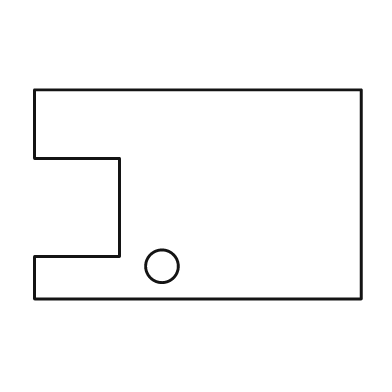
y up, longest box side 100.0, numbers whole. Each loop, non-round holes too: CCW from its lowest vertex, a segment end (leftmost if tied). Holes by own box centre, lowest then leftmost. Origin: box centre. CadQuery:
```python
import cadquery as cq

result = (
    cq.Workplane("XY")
    .moveTo(-50.0, -32.0)
    .lineTo(50.0, -32.0)
    .lineTo(50.0, 32.0)
    .lineTo(-50.0, 32.0)
    .lineTo(-50.0, 11.0)
    .lineTo(-24.0, 11.0)
    .lineTo(-24.0, -19.0)
    .lineTo(-50.0, -19.0)
    .close()
    .moveTo(-11.0, -22.0)
    .circle(5.0)
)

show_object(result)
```